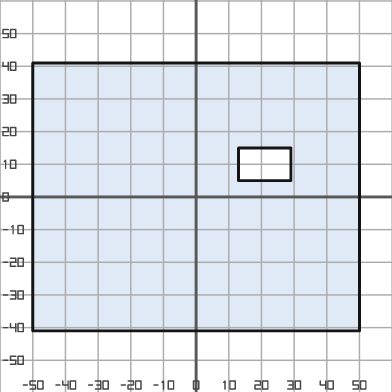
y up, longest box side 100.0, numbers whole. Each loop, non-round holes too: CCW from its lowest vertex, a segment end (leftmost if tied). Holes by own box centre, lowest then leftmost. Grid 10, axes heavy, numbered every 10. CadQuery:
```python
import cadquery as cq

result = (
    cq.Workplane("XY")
    .moveTo(-50.0, -41.0)
    .lineTo(50.0, -41.0)
    .lineTo(50.0, 41.0)
    .lineTo(-50.0, 41.0)
    .close()
    .moveTo(13.0, 5.0)
    .lineTo(29.0, 5.0)
    .lineTo(29.0, 15.0)
    .lineTo(13.0, 15.0)
    .close()
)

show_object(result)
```